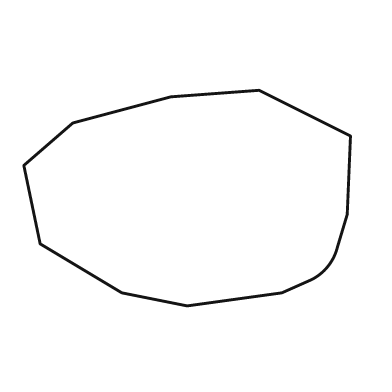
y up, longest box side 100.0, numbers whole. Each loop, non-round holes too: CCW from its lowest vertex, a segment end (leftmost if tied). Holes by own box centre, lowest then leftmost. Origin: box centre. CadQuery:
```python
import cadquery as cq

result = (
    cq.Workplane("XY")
    .moveTo(0.0, -33.0)
    .lineTo(29.0, -29.0)
    .lineTo(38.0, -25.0)
    .threePointArc((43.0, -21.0), (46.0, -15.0))
    .lineTo(49.0, -5.0)
    .lineTo(50.0, 19.0)
    .lineTo(22.0, 33.0)
    .lineTo(-5.0, 31.0)
    .lineTo(-35.0, 23.0)
    .lineTo(-50.0, 10.0)
    .lineTo(-45.0, -14.0)
    .lineTo(-20.0, -29.0)
    .close()
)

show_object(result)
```